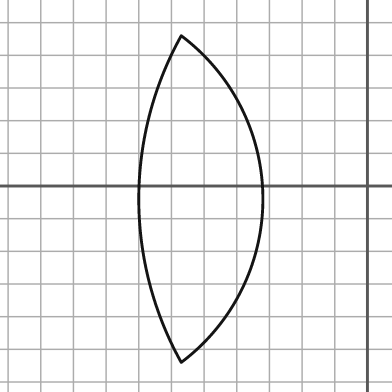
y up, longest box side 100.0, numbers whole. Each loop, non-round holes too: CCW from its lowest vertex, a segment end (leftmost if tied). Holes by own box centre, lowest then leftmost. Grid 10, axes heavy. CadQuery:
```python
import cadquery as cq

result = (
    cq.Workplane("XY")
    .moveTo(-57.0, -54.0)
    .threePointArc((-32.0, -4.0), (-57.0, 46.0))
    .threePointArc((-70.0, -4.0), (-57.0, -54.0))
    .close()
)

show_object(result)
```